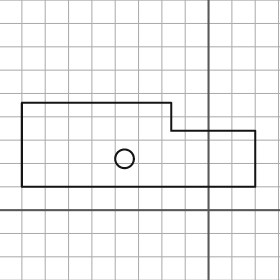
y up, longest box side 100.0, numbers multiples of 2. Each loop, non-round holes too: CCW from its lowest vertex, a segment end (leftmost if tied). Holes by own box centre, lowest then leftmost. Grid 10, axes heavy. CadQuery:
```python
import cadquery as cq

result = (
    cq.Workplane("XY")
    .moveTo(-80.0, 10.0)
    .lineTo(20.0, 10.0)
    .lineTo(20.0, 34.0)
    .lineTo(-16.0, 34.0)
    .lineTo(-16.0, 46.0)
    .lineTo(-80.0, 46.0)
    .close()
    .moveTo(-36.0, 22.0)
    .circle(4.0)
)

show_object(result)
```